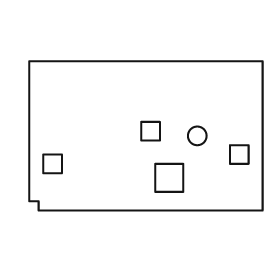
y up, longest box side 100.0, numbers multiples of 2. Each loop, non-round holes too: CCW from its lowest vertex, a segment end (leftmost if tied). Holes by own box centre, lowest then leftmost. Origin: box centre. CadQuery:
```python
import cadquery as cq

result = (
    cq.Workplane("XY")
    .moveTo(-46.0, -32.0)
    .lineTo(50.0, -32.0)
    .lineTo(50.0, 32.0)
    .lineTo(-50.0, 32.0)
    .lineTo(-50.0, -28.0)
    .lineTo(-46.0, -28.0)
    .close()
    .moveTo(4.0, -24.0)
    .lineTo(16.0, -24.0)
    .lineTo(16.0, -12.0)
    .lineTo(4.0, -12.0)
    .close()
    .moveTo(-44.0, -16.0)
    .lineTo(-36.0, -16.0)
    .lineTo(-36.0, -8.0)
    .lineTo(-44.0, -8.0)
    .close()
    .moveTo(36.0, -12.0)
    .lineTo(44.0, -12.0)
    .lineTo(44.0, -4.0)
    .lineTo(36.0, -4.0)
    .close()
    .moveTo(22.0, 0.0)
    .circle(4.0)
    .moveTo(-2.0, -2.0)
    .lineTo(6.0, -2.0)
    .lineTo(6.0, 6.0)
    .lineTo(-2.0, 6.0)
    .close()
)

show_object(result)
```